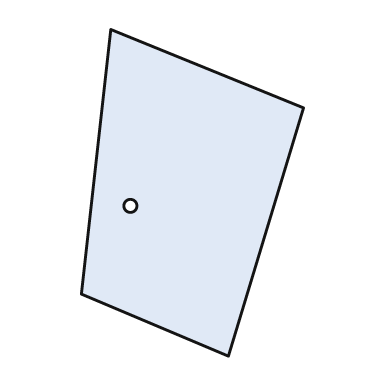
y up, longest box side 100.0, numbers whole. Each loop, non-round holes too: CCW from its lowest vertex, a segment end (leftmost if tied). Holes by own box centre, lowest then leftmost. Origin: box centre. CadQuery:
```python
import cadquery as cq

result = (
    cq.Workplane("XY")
    .moveTo(11.0, -50.0)
    .lineTo(34.0, 26.0)
    .lineTo(-25.0, 50.0)
    .lineTo(-34.0, -31.0)
    .close()
    .moveTo(-19.0, -4.0)
    .circle(2.0)
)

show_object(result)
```